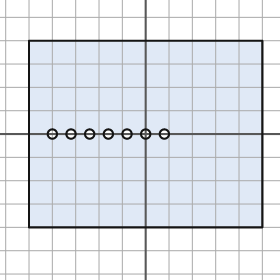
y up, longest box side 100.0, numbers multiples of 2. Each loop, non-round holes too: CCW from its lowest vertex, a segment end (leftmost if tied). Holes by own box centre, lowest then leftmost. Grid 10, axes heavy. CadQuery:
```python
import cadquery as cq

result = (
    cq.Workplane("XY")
    .moveTo(-50.0, -40.0)
    .lineTo(50.0, -40.0)
    .lineTo(50.0, 40.0)
    .lineTo(-50.0, 40.0)
    .close()
    .moveTo(-40.0, 0.0)
    .circle(2.0)
    .moveTo(-32.0, 0.0)
    .circle(2.0)
    .moveTo(-24.0, 0.0)
    .circle(2.0)
    .moveTo(-16.0, 0.0)
    .circle(2.0)
    .moveTo(-8.0, 0.0)
    .circle(2.0)
    .moveTo(0.0, 0.0)
    .circle(2.0)
    .moveTo(8.0, 0.0)
    .circle(2.0)
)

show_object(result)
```